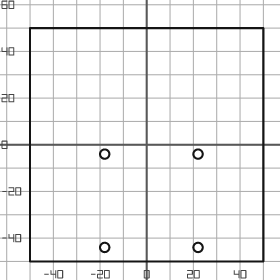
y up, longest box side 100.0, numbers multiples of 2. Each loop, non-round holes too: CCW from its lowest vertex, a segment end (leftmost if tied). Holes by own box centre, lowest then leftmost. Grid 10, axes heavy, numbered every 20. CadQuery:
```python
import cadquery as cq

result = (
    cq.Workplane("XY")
    .moveTo(-50.0, -50.0)
    .lineTo(50.0, -50.0)
    .lineTo(50.0, 50.0)
    .lineTo(-50.0, 50.0)
    .close()
    .moveTo(-18.0, -44.0)
    .circle(2.0)
    .moveTo(22.0, -44.0)
    .circle(2.0)
    .moveTo(-18.0, -4.0)
    .circle(2.0)
    .moveTo(22.0, -4.0)
    .circle(2.0)
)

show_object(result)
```